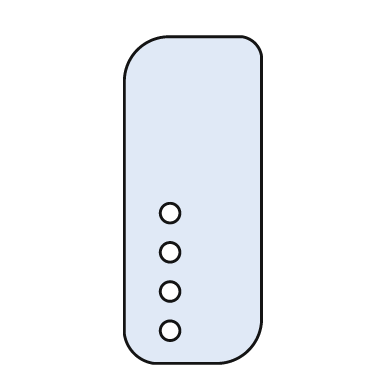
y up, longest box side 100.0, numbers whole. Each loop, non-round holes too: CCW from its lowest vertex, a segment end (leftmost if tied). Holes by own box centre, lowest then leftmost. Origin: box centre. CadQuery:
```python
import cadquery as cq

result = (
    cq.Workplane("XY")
    .moveTo(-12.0, -50.0)
    .lineTo(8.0, -50.0)
    .threePointArc((17.0, -46.0), (21.0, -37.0))
    .lineTo(21.0, 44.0)
    .threePointArc((19.0, 48.0), (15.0, 50.0))
    .lineTo(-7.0, 50.0)
    .threePointArc((-17.0, 46.0), (-21.0, 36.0))
    .lineTo(-21.0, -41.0)
    .threePointArc((-18.0, -47.0), (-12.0, -50.0))
    .close()
    .moveTo(-7.0, -40.0)
    .circle(3.0)
    .moveTo(-7.0, -28.0)
    .circle(3.0)
    .moveTo(-7.0, -16.0)
    .circle(3.0)
    .moveTo(-7.0, -4.0)
    .circle(3.0)
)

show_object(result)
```